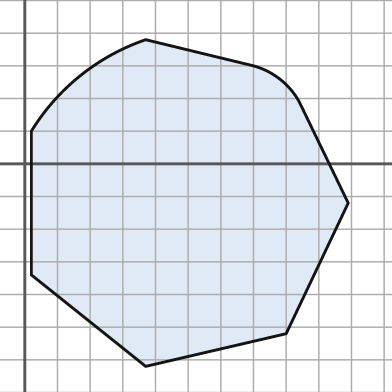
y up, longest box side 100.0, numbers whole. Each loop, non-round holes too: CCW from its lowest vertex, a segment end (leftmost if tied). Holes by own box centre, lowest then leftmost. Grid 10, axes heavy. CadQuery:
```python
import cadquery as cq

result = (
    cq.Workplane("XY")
    .moveTo(37.0, -62.0)
    .lineTo(80.0, -52.0)
    .lineTo(99.0, -12.0)
    .lineTo(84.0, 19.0)
    .threePointArc((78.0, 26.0), (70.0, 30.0))
    .lineTo(37.0, 38.0)
    .threePointArc((17.0, 27.0), (2.0, 10.0))
    .lineTo(2.0, -34.0)
    .close()
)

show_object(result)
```